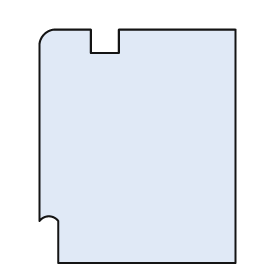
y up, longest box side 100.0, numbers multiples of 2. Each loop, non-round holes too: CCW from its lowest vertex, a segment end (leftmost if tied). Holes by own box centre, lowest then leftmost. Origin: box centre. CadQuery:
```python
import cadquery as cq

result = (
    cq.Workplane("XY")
    .moveTo(-34.0, -50.0)
    .lineTo(42.0, -50.0)
    .lineTo(42.0, 50.0)
    .lineTo(-8.0, 50.0)
    .lineTo(-8.0, 40.0)
    .lineTo(-20.0, 40.0)
    .lineTo(-20.0, 50.0)
    .lineTo(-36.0, 50.0)
    .threePointArc((-40.0, 48.0), (-42.0, 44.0))
    .lineTo(-42.0, -32.0)
    .threePointArc((-38.0, -30.0), (-34.0, -32.0))
    .close()
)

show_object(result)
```